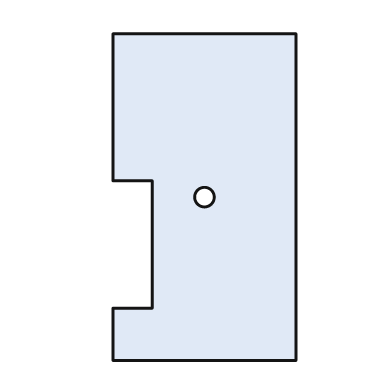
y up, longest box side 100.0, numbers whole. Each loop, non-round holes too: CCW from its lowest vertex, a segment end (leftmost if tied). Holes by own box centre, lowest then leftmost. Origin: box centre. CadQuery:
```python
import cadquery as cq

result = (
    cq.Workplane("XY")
    .moveTo(-28.0, -50.0)
    .lineTo(28.0, -50.0)
    .lineTo(28.0, 50.0)
    .lineTo(-28.0, 50.0)
    .lineTo(-28.0, 5.0)
    .lineTo(-16.0, 5.0)
    .lineTo(-16.0, -34.0)
    .lineTo(-28.0, -34.0)
    .close()
    .moveTo(0.0, 0.0)
    .circle(3.0)
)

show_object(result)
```